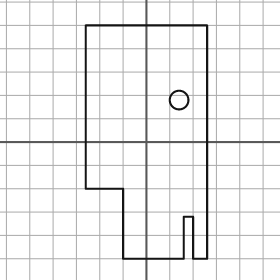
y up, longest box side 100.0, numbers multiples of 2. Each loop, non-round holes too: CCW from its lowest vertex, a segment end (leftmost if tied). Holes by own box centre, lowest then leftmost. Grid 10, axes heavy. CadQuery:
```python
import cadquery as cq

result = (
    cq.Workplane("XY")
    .moveTo(-10.0, -50.0)
    .lineTo(16.0, -50.0)
    .lineTo(16.0, -32.0)
    .lineTo(20.0, -32.0)
    .lineTo(20.0, -50.0)
    .lineTo(26.0, -50.0)
    .lineTo(26.0, 50.0)
    .lineTo(-26.0, 50.0)
    .lineTo(-26.0, -20.0)
    .lineTo(-10.0, -20.0)
    .close()
    .moveTo(14.0, 18.0)
    .circle(4.0)
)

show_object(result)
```